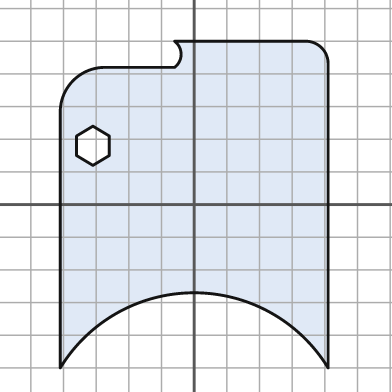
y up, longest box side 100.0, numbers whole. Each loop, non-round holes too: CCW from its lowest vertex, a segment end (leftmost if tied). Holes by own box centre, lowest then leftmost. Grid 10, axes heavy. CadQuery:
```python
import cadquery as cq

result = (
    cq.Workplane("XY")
    .moveTo(-41.0, -50.0)
    .threePointArc((0.0, -27.0), (41.0, -50.0))
    .lineTo(41.0, 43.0)
    .threePointArc((39.0, 48.0), (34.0, 50.0))
    .lineTo(-6.0, 50.0)
    .threePointArc((-4.0, 46.0), (-6.0, 42.0))
    .lineTo(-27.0, 42.0)
    .threePointArc((-37.0, 38.0), (-41.0, 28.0))
    .close()
    .moveTo(-31.0, 12.0)
    .lineTo(-26.0, 15.0)
    .lineTo(-26.0, 21.0)
    .lineTo(-31.0, 24.0)
    .lineTo(-36.0, 21.0)
    .lineTo(-36.0, 15.0)
    .close()
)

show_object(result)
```